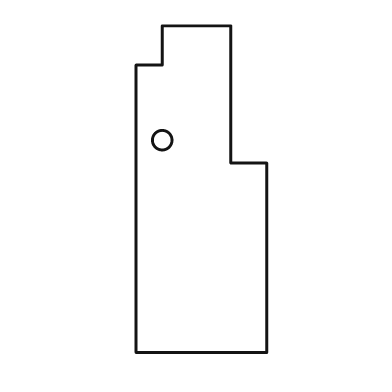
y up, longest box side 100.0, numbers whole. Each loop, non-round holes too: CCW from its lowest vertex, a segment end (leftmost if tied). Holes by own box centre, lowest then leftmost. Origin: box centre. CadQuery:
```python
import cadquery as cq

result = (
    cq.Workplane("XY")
    .moveTo(-20.0, -50.0)
    .lineTo(20.0, -50.0)
    .lineTo(20.0, 8.0)
    .lineTo(9.0, 8.0)
    .lineTo(9.0, 50.0)
    .lineTo(-12.0, 50.0)
    .lineTo(-12.0, 38.0)
    .lineTo(-20.0, 38.0)
    .close()
    .moveTo(-12.0, 15.0)
    .circle(3.0)
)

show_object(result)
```